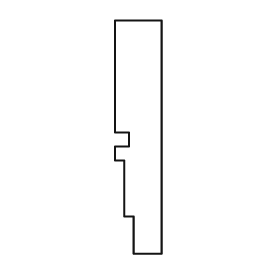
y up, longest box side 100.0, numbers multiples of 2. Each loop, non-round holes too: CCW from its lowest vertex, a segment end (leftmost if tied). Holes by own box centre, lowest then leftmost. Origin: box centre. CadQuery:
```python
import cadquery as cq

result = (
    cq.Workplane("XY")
    .moveTo(-2.0, -50.0)
    .lineTo(10.0, -50.0)
    .lineTo(10.0, 50.0)
    .lineTo(-10.0, 50.0)
    .lineTo(-10.0, 2.0)
    .lineTo(-4.0, 2.0)
    .lineTo(-4.0, -4.0)
    .lineTo(-10.0, -4.0)
    .lineTo(-10.0, -10.0)
    .lineTo(-6.0, -10.0)
    .lineTo(-6.0, -34.0)
    .lineTo(-2.0, -34.0)
    .close()
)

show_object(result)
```